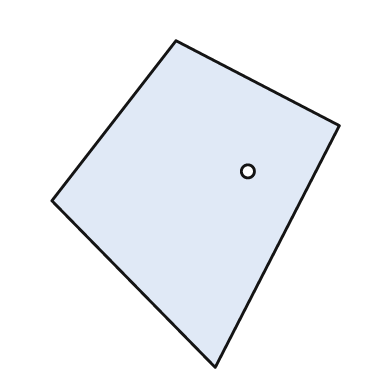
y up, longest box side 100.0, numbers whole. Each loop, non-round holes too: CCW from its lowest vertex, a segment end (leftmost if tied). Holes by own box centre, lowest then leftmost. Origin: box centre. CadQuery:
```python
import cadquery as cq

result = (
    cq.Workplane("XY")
    .moveTo(6.0, -50.0)
    .lineTo(44.0, 24.0)
    .lineTo(-6.0, 50.0)
    .lineTo(-44.0, 1.0)
    .close()
    .moveTo(16.0, 10.0)
    .circle(2.0)
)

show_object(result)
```